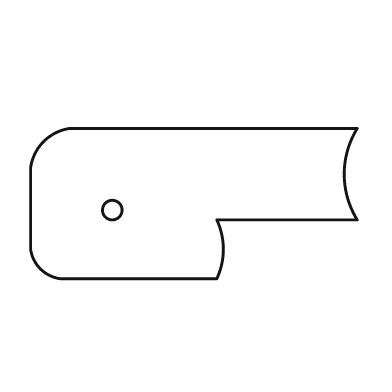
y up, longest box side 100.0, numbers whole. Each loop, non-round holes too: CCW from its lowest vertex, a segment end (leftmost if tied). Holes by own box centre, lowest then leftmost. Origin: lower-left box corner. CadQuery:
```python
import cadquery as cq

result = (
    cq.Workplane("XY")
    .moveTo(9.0, 0.0)
    .lineTo(57.0, 0.0)
    .threePointArc((59.0, 9.0), (57.0, 18.0))
    .lineTo(100.0, 18.0)
    .threePointArc((96.0, 32.0), (100.0, 46.0))
    .lineTo(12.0, 46.0)
    .threePointArc((4.0, 42.0), (0.0, 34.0))
    .lineTo(0.0, 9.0)
    .threePointArc((3.0, 3.0), (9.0, 0.0))
    .close()
    .moveTo(25.0, 21.0)
    .circle(3.0)
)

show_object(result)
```